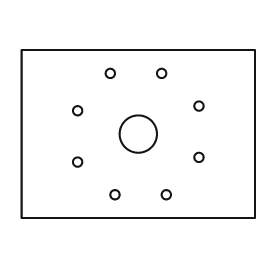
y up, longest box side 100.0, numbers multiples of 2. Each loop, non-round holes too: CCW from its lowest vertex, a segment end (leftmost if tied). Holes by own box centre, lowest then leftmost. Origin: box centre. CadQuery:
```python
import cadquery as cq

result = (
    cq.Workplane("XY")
    .moveTo(-50.0, -36.0)
    .lineTo(50.0, -36.0)
    .lineTo(50.0, 36.0)
    .lineTo(-50.0, 36.0)
    .close()
    .moveTo(-10.0, -26.0)
    .circle(2.0)
    .moveTo(12.0, -26.0)
    .circle(2.0)
    .moveTo(-26.0, -12.0)
    .circle(2.0)
    .moveTo(26.0, -10.0)
    .circle(2.0)
    .moveTo(0.0, 0.0)
    .circle(8.0)
    .moveTo(-26.0, 10.0)
    .circle(2.0)
    .moveTo(26.0, 12.0)
    .circle(2.0)
    .moveTo(-12.0, 26.0)
    .circle(2.0)
    .moveTo(10.0, 26.0)
    .circle(2.0)
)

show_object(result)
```